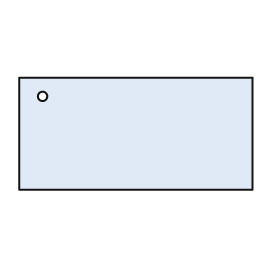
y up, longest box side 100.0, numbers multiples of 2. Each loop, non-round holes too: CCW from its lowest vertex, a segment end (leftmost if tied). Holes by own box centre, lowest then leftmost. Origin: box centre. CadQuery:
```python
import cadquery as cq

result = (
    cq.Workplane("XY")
    .moveTo(-50.0, -24.0)
    .lineTo(50.0, -24.0)
    .lineTo(50.0, 24.0)
    .lineTo(-50.0, 24.0)
    .close()
    .moveTo(-40.0, 16.0)
    .circle(2.0)
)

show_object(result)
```